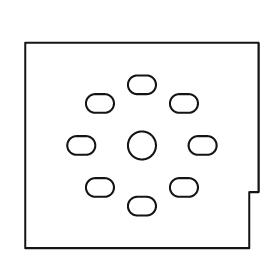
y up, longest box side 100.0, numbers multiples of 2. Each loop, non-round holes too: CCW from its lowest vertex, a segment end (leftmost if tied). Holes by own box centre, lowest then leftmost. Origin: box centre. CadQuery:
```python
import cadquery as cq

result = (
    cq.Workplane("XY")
    .moveTo(-50.0, -44.0)
    .lineTo(46.0, -44.0)
    .lineTo(46.0, -20.0)
    .lineTo(50.0, -20.0)
    .lineTo(50.0, 44.0)
    .lineTo(-50.0, 44.0)
    .close()
    .moveTo(-2.0, -30.0)
    .lineTo(2.0, -30.0)
    .threePointArc((6.0, -26.0), (2.0, -22.0))
    .lineTo(-2.0, -22.0)
    .threePointArc((-6.0, -26.0), (-2.0, -30.0))
    .close()
    .moveTo(-20.0, -22.0)
    .lineTo(-16.0, -22.0)
    .threePointArc((-12.0, -18.0), (-16.0, -14.0))
    .lineTo(-20.0, -14.0)
    .threePointArc((-24.0, -18.0), (-20.0, -22.0))
    .close()
    .moveTo(16.0, -22.0)
    .lineTo(20.0, -22.0)
    .threePointArc((24.0, -18.0), (20.0, -14.0))
    .lineTo(16.0, -14.0)
    .threePointArc((12.0, -18.0), (16.0, -22.0))
    .close()
    .moveTo(-28.0, -4.0)
    .lineTo(-24.0, -4.0)
    .threePointArc((-20.0, 0.0), (-24.0, 4.0))
    .lineTo(-28.0, 4.0)
    .threePointArc((-32.0, 0.0), (-28.0, -4.0))
    .close()
    .moveTo(0.0, 0.0)
    .circle(6.0)
    .moveTo(24.0, -4.0)
    .lineTo(28.0, -4.0)
    .threePointArc((32.0, 0.0), (28.0, 4.0))
    .lineTo(24.0, 4.0)
    .threePointArc((20.0, 0.0), (24.0, -4.0))
    .close()
    .moveTo(-20.0, 14.0)
    .lineTo(-16.0, 14.0)
    .threePointArc((-12.0, 18.0), (-16.0, 22.0))
    .lineTo(-20.0, 22.0)
    .threePointArc((-24.0, 18.0), (-20.0, 14.0))
    .close()
    .moveTo(16.0, 14.0)
    .lineTo(20.0, 14.0)
    .threePointArc((24.0, 18.0), (20.0, 22.0))
    .lineTo(16.0, 22.0)
    .threePointArc((12.0, 18.0), (16.0, 14.0))
    .close()
    .moveTo(-2.0, 22.0)
    .lineTo(2.0, 22.0)
    .threePointArc((6.0, 26.0), (2.0, 30.0))
    .lineTo(-2.0, 30.0)
    .threePointArc((-6.0, 26.0), (-2.0, 22.0))
    .close()
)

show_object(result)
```